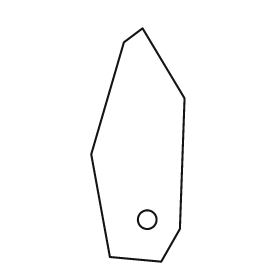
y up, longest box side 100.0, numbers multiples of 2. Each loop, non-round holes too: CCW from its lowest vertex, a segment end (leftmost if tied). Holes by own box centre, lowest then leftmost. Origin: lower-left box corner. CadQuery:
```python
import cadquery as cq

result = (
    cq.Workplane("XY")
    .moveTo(30.0, 0.0)
    .lineTo(38.0, 14.0)
    .lineTo(40.0, 70.0)
    .lineTo(22.0, 100.0)
    .lineTo(14.0, 94.0)
    .lineTo(0.0, 46.0)
    .lineTo(8.0, 2.0)
    .close()
    .moveTo(24.0, 18.0)
    .circle(4.0)
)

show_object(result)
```